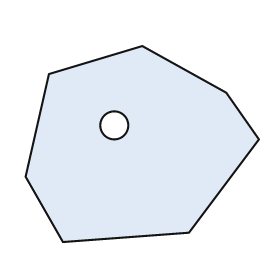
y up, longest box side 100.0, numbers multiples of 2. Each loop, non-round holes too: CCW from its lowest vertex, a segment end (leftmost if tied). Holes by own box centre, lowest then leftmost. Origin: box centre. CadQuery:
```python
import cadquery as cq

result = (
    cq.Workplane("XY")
    .moveTo(-34.0, -42.0)
    .lineTo(20.0, -38.0)
    .lineTo(50.0, 2.0)
    .lineTo(36.0, 22.0)
    .lineTo(0.0, 42.0)
    .lineTo(-40.0, 30.0)
    .lineTo(-50.0, -14.0)
    .close()
    .moveTo(-12.0, 8.0)
    .circle(6.0)
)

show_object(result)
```